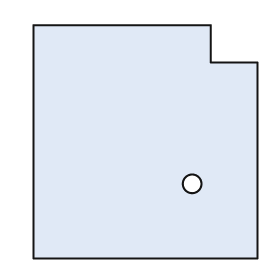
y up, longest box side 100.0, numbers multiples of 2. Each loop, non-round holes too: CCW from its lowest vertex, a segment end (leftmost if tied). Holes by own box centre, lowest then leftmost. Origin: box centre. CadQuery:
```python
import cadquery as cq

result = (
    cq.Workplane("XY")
    .moveTo(-48.0, -50.0)
    .lineTo(48.0, -50.0)
    .lineTo(48.0, 34.0)
    .lineTo(28.0, 34.0)
    .lineTo(28.0, 50.0)
    .lineTo(-48.0, 50.0)
    .close()
    .moveTo(20.0, -18.0)
    .circle(4.0)
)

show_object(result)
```